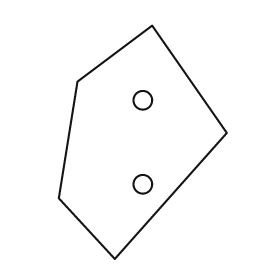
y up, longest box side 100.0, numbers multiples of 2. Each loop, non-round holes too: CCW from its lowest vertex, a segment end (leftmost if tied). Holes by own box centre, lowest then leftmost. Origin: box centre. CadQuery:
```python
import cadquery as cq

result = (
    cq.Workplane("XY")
    .moveTo(-12.0, -50.0)
    .lineTo(36.0, 4.0)
    .lineTo(4.0, 50.0)
    .lineTo(-28.0, 26.0)
    .lineTo(-36.0, -24.0)
    .close()
    .moveTo(0.0, -18.0)
    .circle(4.0)
    .moveTo(0.0, 18.0)
    .circle(4.0)
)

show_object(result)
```